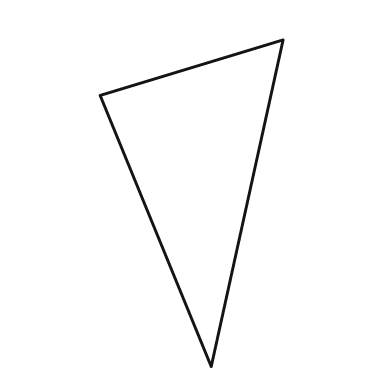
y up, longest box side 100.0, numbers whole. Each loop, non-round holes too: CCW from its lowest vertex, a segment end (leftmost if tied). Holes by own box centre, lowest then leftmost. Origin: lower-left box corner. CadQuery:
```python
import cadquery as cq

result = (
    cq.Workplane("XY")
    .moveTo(34.0, 0.0)
    .lineTo(56.0, 100.0)
    .lineTo(0.0, 83.0)
    .close()
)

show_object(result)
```